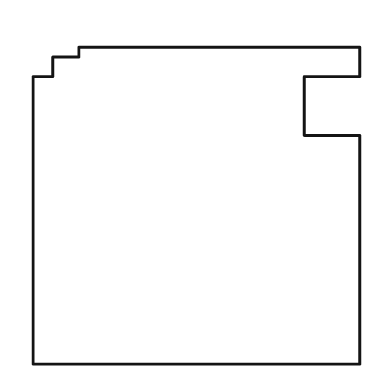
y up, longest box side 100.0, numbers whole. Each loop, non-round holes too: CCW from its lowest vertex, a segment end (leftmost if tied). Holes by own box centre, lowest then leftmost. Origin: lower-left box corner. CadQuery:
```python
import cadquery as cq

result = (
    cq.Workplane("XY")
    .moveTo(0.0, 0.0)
    .lineTo(100.0, 0.0)
    .lineTo(100.0, 70.0)
    .lineTo(83.0, 70.0)
    .lineTo(83.0, 88.0)
    .lineTo(100.0, 88.0)
    .lineTo(100.0, 97.0)
    .lineTo(14.0, 97.0)
    .lineTo(14.0, 94.0)
    .lineTo(6.0, 94.0)
    .lineTo(6.0, 88.0)
    .lineTo(0.0, 88.0)
    .close()
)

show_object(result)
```